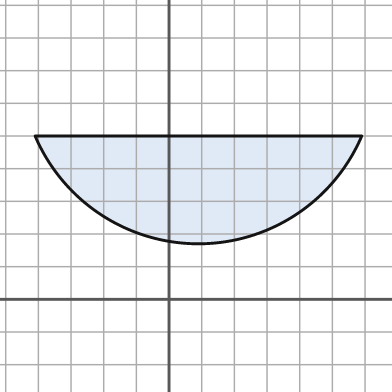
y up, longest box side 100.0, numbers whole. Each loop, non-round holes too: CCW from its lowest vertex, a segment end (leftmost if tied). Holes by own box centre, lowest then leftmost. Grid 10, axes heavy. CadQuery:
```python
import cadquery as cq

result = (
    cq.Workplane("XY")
    .moveTo(-41.0, 50.0)
    .threePointArc((9.0, 17.0), (59.0, 50.0))
    .close()
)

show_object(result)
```